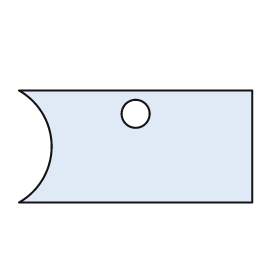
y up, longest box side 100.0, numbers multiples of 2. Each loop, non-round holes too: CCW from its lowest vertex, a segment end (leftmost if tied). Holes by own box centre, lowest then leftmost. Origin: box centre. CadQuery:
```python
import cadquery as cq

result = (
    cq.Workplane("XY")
    .moveTo(-50.0, -24.0)
    .lineTo(50.0, -24.0)
    .lineTo(50.0, 24.0)
    .lineTo(-50.0, 24.0)
    .threePointArc((-36.0, 0.0), (-50.0, -24.0))
    .close()
    .moveTo(0.0, 14.0)
    .circle(6.0)
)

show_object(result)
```